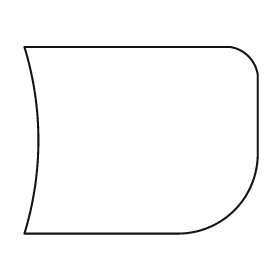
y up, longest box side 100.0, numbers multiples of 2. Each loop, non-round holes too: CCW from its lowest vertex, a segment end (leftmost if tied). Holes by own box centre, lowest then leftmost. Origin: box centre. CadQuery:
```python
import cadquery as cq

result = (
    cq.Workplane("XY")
    .moveTo(-50.0, -40.0)
    .lineTo(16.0, -40.0)
    .threePointArc((40.0, -30.0), (50.0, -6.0))
    .lineTo(50.0, 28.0)
    .threePointArc((46.0, 36.0), (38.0, 40.0))
    .lineTo(-50.0, 40.0)
    .threePointArc((-44.0, 0.0), (-50.0, -40.0))
    .close()
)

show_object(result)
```